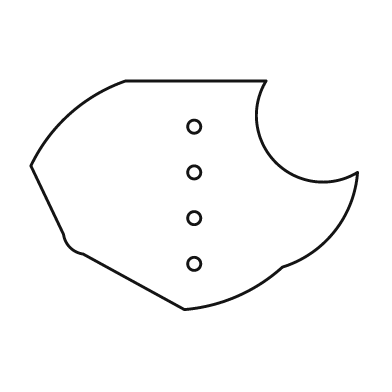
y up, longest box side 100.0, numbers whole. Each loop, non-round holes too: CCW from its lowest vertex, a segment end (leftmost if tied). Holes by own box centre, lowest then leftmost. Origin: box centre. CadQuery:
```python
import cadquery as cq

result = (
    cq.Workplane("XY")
    .moveTo(-3.0, -35.0)
    .threePointArc((13.0, -31.0), (27.0, -22.0))
    .threePointArc((43.0, -11.0), (50.0, 7.0))
    .threePointArc((25.0, 10.0), (22.0, 35.0))
    .lineTo(-21.0, 35.0)
    .threePointArc((-38.0, 25.0), (-50.0, 9.0))
    .lineTo(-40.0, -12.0)
    .threePointArc((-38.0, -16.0), (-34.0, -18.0))
    .close()
    .moveTo(0.0, -21.0)
    .circle(2.0)
    .moveTo(0.0, -7.0)
    .circle(2.0)
    .moveTo(0.0, 7.0)
    .circle(2.0)
    .moveTo(0.0, 21.0)
    .circle(2.0)
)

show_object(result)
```